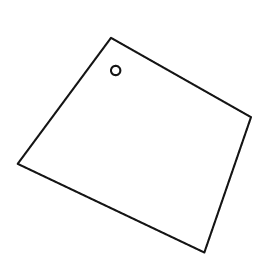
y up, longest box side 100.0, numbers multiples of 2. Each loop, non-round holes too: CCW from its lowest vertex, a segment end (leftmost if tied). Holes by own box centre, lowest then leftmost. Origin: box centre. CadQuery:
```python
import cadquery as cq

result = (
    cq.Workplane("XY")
    .moveTo(30.0, -46.0)
    .lineTo(50.0, 12.0)
    .lineTo(-10.0, 46.0)
    .lineTo(-50.0, -8.0)
    .close()
    .moveTo(-8.0, 32.0)
    .circle(2.0)
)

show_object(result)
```